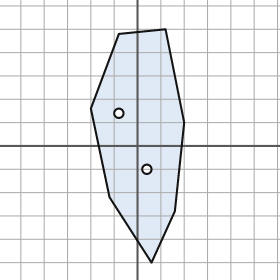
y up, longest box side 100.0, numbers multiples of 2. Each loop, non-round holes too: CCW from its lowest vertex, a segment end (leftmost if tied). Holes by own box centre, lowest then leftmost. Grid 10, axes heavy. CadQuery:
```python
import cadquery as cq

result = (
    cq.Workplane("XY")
    .moveTo(6.0, -50.0)
    .lineTo(16.0, -28.0)
    .lineTo(20.0, 10.0)
    .lineTo(12.0, 50.0)
    .lineTo(-8.0, 48.0)
    .lineTo(-20.0, 16.0)
    .lineTo(-12.0, -22.0)
    .close()
    .moveTo(4.0, -10.0)
    .circle(2.0)
    .moveTo(-8.0, 14.0)
    .circle(2.0)
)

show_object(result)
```